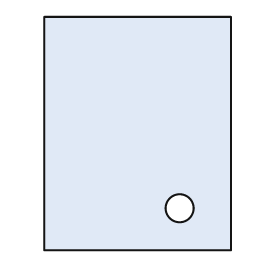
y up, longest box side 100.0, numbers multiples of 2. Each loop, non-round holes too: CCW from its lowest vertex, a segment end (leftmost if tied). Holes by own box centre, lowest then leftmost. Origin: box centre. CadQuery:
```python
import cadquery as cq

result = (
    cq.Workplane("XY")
    .moveTo(-40.0, -50.0)
    .lineTo(40.0, -50.0)
    .lineTo(40.0, 50.0)
    .lineTo(-40.0, 50.0)
    .close()
    .moveTo(18.0, -32.0)
    .circle(6.0)
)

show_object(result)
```